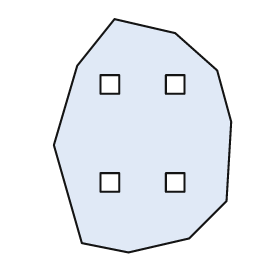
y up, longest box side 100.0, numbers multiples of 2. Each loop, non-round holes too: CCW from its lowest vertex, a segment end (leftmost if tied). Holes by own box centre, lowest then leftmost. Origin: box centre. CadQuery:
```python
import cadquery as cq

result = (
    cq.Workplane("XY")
    .moveTo(-6.0, -50.0)
    .lineTo(20.0, -44.0)
    .lineTo(36.0, -28.0)
    .lineTo(38.0, 6.0)
    .lineTo(32.0, 28.0)
    .lineTo(14.0, 44.0)
    .lineTo(-12.0, 50.0)
    .lineTo(-28.0, 30.0)
    .lineTo(-38.0, -4.0)
    .lineTo(-26.0, -46.0)
    .close()
    .moveTo(-18.0, -24.0)
    .lineTo(-10.0, -24.0)
    .lineTo(-10.0, -16.0)
    .lineTo(-18.0, -16.0)
    .close()
    .moveTo(10.0, -24.0)
    .lineTo(18.0, -24.0)
    .lineTo(18.0, -16.0)
    .lineTo(10.0, -16.0)
    .close()
    .moveTo(-18.0, 18.0)
    .lineTo(-10.0, 18.0)
    .lineTo(-10.0, 26.0)
    .lineTo(-18.0, 26.0)
    .close()
    .moveTo(10.0, 18.0)
    .lineTo(18.0, 18.0)
    .lineTo(18.0, 26.0)
    .lineTo(10.0, 26.0)
    .close()
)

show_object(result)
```